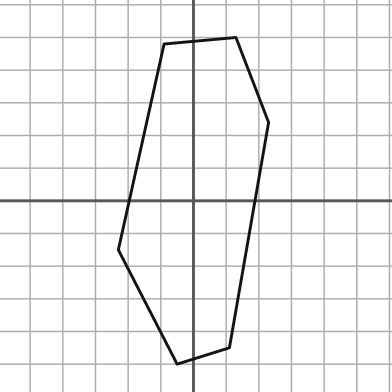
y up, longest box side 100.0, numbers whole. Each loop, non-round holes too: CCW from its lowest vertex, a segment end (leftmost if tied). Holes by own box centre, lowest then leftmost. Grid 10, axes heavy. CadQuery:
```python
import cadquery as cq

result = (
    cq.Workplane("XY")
    .moveTo(-5.0, -50.0)
    .lineTo(11.0, -45.0)
    .lineTo(23.0, 24.0)
    .lineTo(13.0, 50.0)
    .lineTo(-9.0, 48.0)
    .lineTo(-23.0, -15.0)
    .close()
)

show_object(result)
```